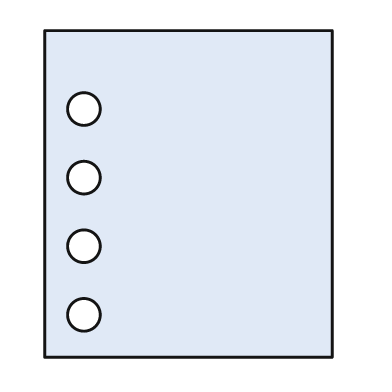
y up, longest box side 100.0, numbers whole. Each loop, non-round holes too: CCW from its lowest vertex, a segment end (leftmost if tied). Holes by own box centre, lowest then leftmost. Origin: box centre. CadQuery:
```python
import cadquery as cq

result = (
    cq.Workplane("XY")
    .moveTo(-44.0, -50.0)
    .lineTo(44.0, -50.0)
    .lineTo(44.0, 50.0)
    .lineTo(-44.0, 50.0)
    .close()
    .moveTo(-32.0, -37.0)
    .circle(5.0)
    .moveTo(-32.0, -16.0)
    .circle(5.0)
    .moveTo(-32.0, 5.0)
    .circle(5.0)
    .moveTo(-32.0, 26.0)
    .circle(5.0)
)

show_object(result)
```